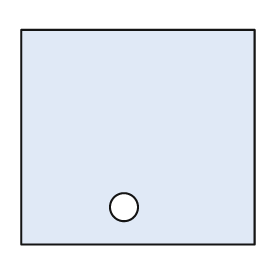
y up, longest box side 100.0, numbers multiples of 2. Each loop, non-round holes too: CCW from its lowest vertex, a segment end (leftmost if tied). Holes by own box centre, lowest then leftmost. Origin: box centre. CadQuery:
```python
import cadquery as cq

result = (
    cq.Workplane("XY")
    .moveTo(-50.0, -46.0)
    .lineTo(50.0, -46.0)
    .lineTo(50.0, 46.0)
    .lineTo(-50.0, 46.0)
    .close()
    .moveTo(-6.0, -30.0)
    .circle(6.0)
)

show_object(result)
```